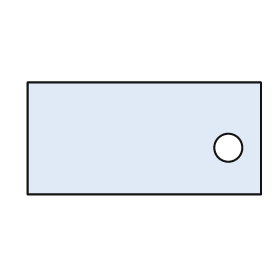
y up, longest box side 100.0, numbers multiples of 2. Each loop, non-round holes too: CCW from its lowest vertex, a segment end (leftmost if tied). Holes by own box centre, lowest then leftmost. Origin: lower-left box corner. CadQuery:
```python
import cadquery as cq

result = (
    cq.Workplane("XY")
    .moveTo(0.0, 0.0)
    .lineTo(100.0, 0.0)
    .lineTo(100.0, 48.0)
    .lineTo(0.0, 48.0)
    .close()
    .moveTo(86.0, 20.0)
    .circle(6.0)
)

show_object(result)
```